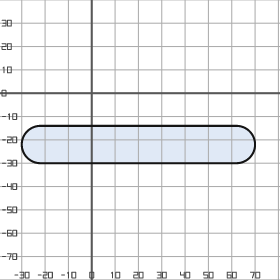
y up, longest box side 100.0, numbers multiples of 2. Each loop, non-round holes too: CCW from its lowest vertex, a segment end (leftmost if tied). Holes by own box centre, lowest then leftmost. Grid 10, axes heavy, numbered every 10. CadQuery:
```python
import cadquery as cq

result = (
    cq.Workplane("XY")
    .moveTo(-22.0, -30.0)
    .lineTo(62.0, -30.0)
    .threePointArc((70.0, -22.0), (62.0, -14.0))
    .lineTo(-22.0, -14.0)
    .threePointArc((-30.0, -22.0), (-22.0, -30.0))
    .close()
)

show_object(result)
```